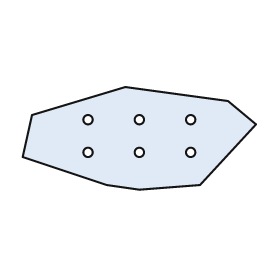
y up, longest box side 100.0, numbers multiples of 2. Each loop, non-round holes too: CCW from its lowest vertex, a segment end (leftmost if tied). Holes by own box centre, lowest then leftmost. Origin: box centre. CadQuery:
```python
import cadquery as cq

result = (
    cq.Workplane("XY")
    .moveTo(0.0, -22.0)
    .lineTo(26.0, -20.0)
    .lineTo(50.0, 6.0)
    .lineTo(38.0, 16.0)
    .lineTo(-6.0, 22.0)
    .lineTo(-46.0, 10.0)
    .lineTo(-50.0, -8.0)
    .lineTo(-14.0, -20.0)
    .close()
    .moveTo(-22.0, -6.0)
    .circle(2.0)
    .moveTo(0.0, -6.0)
    .circle(2.0)
    .moveTo(22.0, -6.0)
    .circle(2.0)
    .moveTo(-22.0, 8.0)
    .circle(2.0)
    .moveTo(0.0, 8.0)
    .circle(2.0)
    .moveTo(22.0, 8.0)
    .circle(2.0)
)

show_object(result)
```